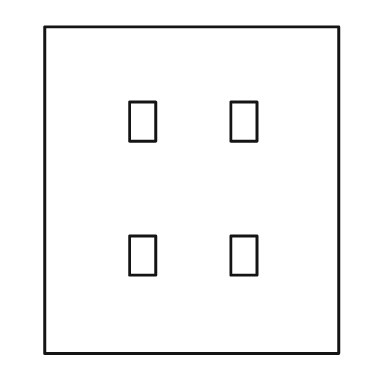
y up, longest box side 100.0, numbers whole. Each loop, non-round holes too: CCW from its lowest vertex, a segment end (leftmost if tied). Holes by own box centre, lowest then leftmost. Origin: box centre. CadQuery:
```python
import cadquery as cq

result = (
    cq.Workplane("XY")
    .moveTo(-45.0, -50.0)
    .lineTo(45.0, -50.0)
    .lineTo(45.0, 50.0)
    .lineTo(-45.0, 50.0)
    .close()
    .moveTo(-19.0, -26.0)
    .lineTo(-11.0, -26.0)
    .lineTo(-11.0, -14.0)
    .lineTo(-19.0, -14.0)
    .close()
    .moveTo(12.0, -26.0)
    .lineTo(20.0, -26.0)
    .lineTo(20.0, -14.0)
    .lineTo(12.0, -14.0)
    .close()
    .moveTo(-19.0, 15.0)
    .lineTo(-11.0, 15.0)
    .lineTo(-11.0, 27.0)
    .lineTo(-19.0, 27.0)
    .close()
    .moveTo(12.0, 15.0)
    .lineTo(20.0, 15.0)
    .lineTo(20.0, 27.0)
    .lineTo(12.0, 27.0)
    .close()
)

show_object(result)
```